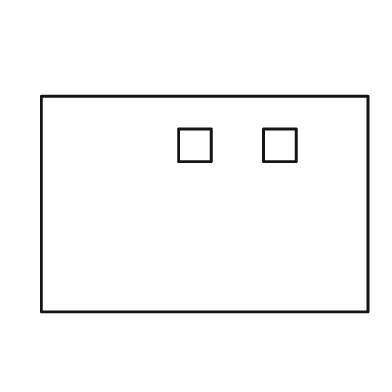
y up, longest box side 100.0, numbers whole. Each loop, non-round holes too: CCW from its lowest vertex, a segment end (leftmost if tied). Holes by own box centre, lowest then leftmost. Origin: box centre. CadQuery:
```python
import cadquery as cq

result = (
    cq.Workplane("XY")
    .moveTo(-50.0, -33.0)
    .lineTo(50.0, -33.0)
    .lineTo(50.0, 33.0)
    .lineTo(-50.0, 33.0)
    .close()
    .moveTo(-8.0, 13.0)
    .lineTo(2.0, 13.0)
    .lineTo(2.0, 23.0)
    .lineTo(-8.0, 23.0)
    .close()
    .moveTo(18.0, 13.0)
    .lineTo(28.0, 13.0)
    .lineTo(28.0, 23.0)
    .lineTo(18.0, 23.0)
    .close()
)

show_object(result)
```